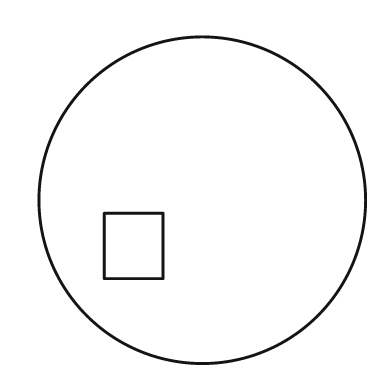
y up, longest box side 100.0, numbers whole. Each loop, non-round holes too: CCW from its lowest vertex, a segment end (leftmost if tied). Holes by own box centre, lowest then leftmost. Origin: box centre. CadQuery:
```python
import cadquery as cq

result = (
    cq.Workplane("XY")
    .moveTo(0.0, 0.0)
    .circle(50.0)
    .moveTo(-30.0, -24.0)
    .lineTo(-12.0, -24.0)
    .lineTo(-12.0, -4.0)
    .lineTo(-30.0, -4.0)
    .close()
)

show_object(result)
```